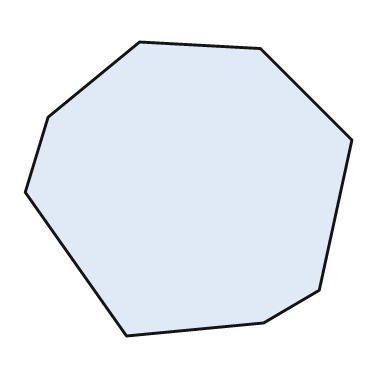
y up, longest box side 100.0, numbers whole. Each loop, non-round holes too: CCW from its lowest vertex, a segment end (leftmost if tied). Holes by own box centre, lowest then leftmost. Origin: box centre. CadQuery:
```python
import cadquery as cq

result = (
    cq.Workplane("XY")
    .moveTo(-19.0, -45.0)
    .lineTo(23.0, -41.0)
    .lineTo(40.0, -31.0)
    .lineTo(50.0, 15.0)
    .lineTo(22.0, 43.0)
    .lineTo(-15.0, 45.0)
    .lineTo(-43.0, 22.0)
    .lineTo(-50.0, -1.0)
    .close()
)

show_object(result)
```